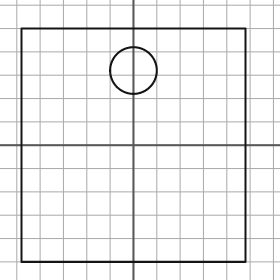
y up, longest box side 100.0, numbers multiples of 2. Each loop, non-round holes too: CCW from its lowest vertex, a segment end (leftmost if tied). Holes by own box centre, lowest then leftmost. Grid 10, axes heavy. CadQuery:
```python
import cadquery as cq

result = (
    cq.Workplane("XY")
    .moveTo(-48.0, -50.0)
    .lineTo(48.0, -50.0)
    .lineTo(48.0, 50.0)
    .lineTo(-48.0, 50.0)
    .close()
    .moveTo(0.0, 32.0)
    .circle(10.0)
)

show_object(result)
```